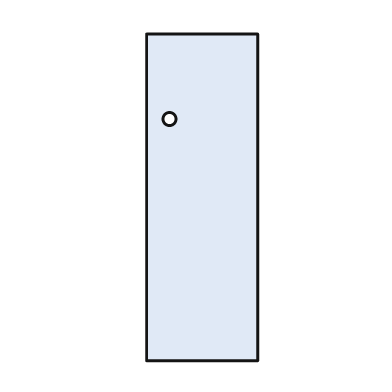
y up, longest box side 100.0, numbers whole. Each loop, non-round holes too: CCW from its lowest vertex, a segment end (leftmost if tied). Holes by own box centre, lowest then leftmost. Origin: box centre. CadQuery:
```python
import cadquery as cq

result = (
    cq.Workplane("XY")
    .moveTo(-17.0, -50.0)
    .lineTo(17.0, -50.0)
    .lineTo(17.0, 50.0)
    .lineTo(-17.0, 50.0)
    .close()
    .moveTo(-10.0, 24.0)
    .circle(2.0)
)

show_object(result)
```